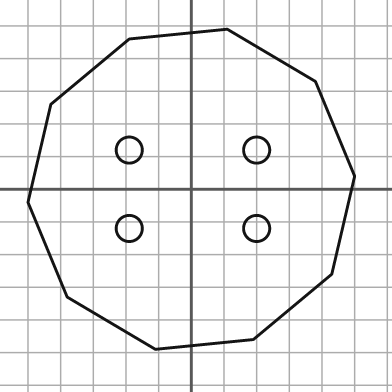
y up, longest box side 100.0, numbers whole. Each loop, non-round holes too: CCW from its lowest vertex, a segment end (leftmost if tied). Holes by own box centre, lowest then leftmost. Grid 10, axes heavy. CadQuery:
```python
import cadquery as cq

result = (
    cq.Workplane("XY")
    .moveTo(-11.0, -49.0)
    .lineTo(19.0, -46.0)
    .lineTo(43.0, -26.0)
    .lineTo(50.0, 4.0)
    .lineTo(38.0, 33.0)
    .lineTo(11.0, 49.0)
    .lineTo(-19.0, 46.0)
    .lineTo(-43.0, 26.0)
    .lineTo(-50.0, -4.0)
    .lineTo(-38.0, -33.0)
    .close()
    .moveTo(-19.0, -12.0)
    .circle(4.0)
    .moveTo(20.0, -12.0)
    .circle(4.0)
    .moveTo(-19.0, 12.0)
    .circle(4.0)
    .moveTo(20.0, 12.0)
    .circle(4.0)
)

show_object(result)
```